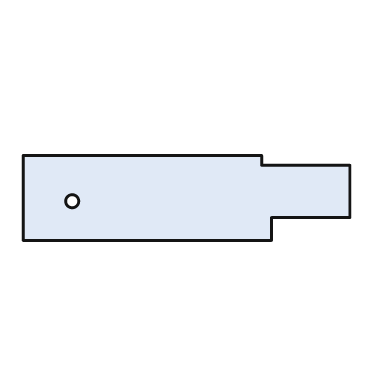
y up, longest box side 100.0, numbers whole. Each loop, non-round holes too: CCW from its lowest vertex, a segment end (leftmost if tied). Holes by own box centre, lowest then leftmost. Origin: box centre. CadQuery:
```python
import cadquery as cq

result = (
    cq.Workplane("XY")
    .moveTo(-50.0, -13.0)
    .lineTo(26.0, -13.0)
    .lineTo(26.0, -6.0)
    .lineTo(50.0, -6.0)
    .lineTo(50.0, 10.0)
    .lineTo(23.0, 10.0)
    .lineTo(23.0, 13.0)
    .lineTo(-50.0, 13.0)
    .close()
    .moveTo(-35.0, -1.0)
    .circle(2.0)
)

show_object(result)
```